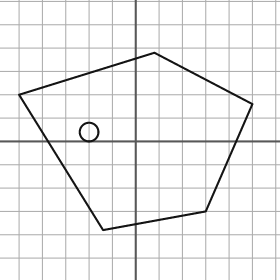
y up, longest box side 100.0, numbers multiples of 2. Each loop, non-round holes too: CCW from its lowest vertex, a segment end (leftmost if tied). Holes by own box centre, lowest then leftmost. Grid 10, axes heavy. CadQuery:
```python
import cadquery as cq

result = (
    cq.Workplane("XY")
    .moveTo(-14.0, -38.0)
    .lineTo(30.0, -30.0)
    .lineTo(50.0, 16.0)
    .lineTo(8.0, 38.0)
    .lineTo(-50.0, 20.0)
    .close()
    .moveTo(-20.0, 4.0)
    .circle(4.0)
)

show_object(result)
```